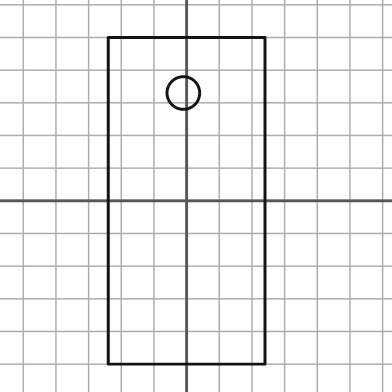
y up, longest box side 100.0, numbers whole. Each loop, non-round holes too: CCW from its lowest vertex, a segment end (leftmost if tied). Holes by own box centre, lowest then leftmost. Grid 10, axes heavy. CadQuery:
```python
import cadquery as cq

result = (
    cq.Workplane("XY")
    .moveTo(-24.0, -50.0)
    .lineTo(24.0, -50.0)
    .lineTo(24.0, 50.0)
    .lineTo(-24.0, 50.0)
    .close()
    .moveTo(-1.0, 33.0)
    .circle(5.0)
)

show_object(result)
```